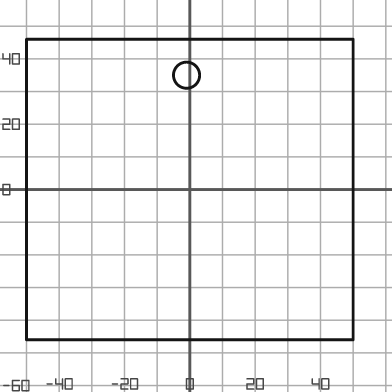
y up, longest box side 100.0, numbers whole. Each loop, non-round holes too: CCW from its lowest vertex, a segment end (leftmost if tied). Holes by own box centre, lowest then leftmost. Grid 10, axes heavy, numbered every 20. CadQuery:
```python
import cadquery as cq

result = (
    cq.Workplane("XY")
    .moveTo(-50.0, -46.0)
    .lineTo(50.0, -46.0)
    .lineTo(50.0, 46.0)
    .lineTo(-50.0, 46.0)
    .close()
    .moveTo(-1.0, 35.0)
    .circle(4.0)
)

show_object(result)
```